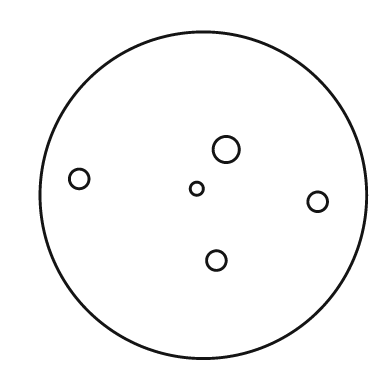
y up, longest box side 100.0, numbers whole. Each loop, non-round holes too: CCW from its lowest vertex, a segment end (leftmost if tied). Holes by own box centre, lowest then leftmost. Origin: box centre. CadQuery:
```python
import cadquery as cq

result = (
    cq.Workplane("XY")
    .moveTo(0.0, 0.0)
    .circle(50.0)
    .moveTo(4.0, -20.0)
    .circle(3.0)
    .moveTo(35.0, -2.0)
    .circle(3.0)
    .moveTo(-2.0, 2.0)
    .circle(2.0)
    .moveTo(-38.0, 5.0)
    .circle(3.0)
    .moveTo(7.0, 14.0)
    .circle(4.0)
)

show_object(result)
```